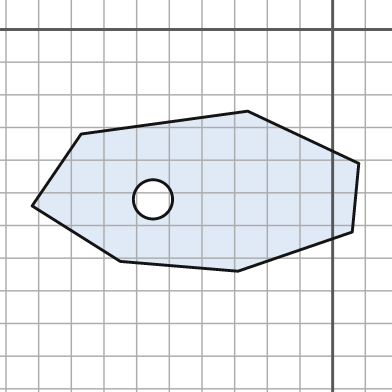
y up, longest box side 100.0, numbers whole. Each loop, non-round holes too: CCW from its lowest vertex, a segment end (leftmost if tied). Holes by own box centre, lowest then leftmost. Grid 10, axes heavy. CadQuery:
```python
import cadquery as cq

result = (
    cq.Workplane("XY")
    .moveTo(-29.0, -74.0)
    .lineTo(6.0, -62.0)
    .lineTo(8.0, -41.0)
    .lineTo(-26.0, -25.0)
    .lineTo(-77.0, -32.0)
    .lineTo(-92.0, -54.0)
    .lineTo(-65.0, -71.0)
    .close()
    .moveTo(-55.0, -52.0)
    .circle(6.0)
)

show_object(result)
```